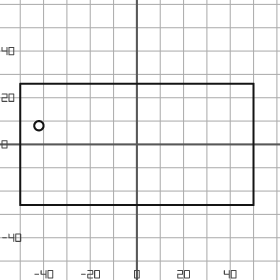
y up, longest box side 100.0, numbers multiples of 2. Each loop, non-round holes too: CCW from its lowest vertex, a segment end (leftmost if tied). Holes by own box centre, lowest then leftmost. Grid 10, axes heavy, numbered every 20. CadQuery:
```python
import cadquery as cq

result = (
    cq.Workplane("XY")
    .moveTo(-50.0, -26.0)
    .lineTo(50.0, -26.0)
    .lineTo(50.0, 26.0)
    .lineTo(-50.0, 26.0)
    .close()
    .moveTo(-42.0, 8.0)
    .circle(2.0)
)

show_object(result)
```